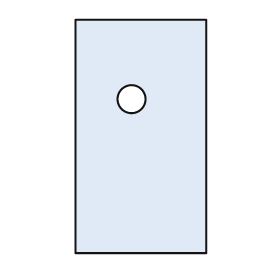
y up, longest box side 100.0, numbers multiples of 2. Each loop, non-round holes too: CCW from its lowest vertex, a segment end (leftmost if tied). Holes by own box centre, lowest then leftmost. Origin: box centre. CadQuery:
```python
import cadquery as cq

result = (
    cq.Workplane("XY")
    .moveTo(-28.0, -50.0)
    .lineTo(28.0, -50.0)
    .lineTo(28.0, 50.0)
    .lineTo(-28.0, 50.0)
    .close()
    .moveTo(-4.0, 16.0)
    .circle(6.0)
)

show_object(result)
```